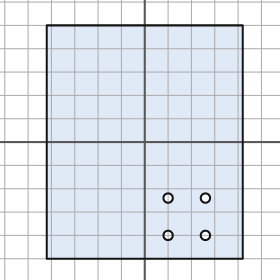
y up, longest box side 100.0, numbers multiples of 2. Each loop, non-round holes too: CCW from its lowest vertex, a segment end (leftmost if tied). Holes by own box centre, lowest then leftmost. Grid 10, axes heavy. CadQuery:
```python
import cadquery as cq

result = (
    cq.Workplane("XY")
    .moveTo(-42.0, -50.0)
    .lineTo(42.0, -50.0)
    .lineTo(42.0, 50.0)
    .lineTo(-42.0, 50.0)
    .close()
    .moveTo(10.0, -40.0)
    .circle(2.0)
    .moveTo(26.0, -40.0)
    .circle(2.0)
    .moveTo(10.0, -24.0)
    .circle(2.0)
    .moveTo(26.0, -24.0)
    .circle(2.0)
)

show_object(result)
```